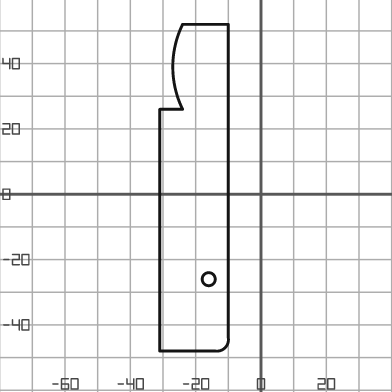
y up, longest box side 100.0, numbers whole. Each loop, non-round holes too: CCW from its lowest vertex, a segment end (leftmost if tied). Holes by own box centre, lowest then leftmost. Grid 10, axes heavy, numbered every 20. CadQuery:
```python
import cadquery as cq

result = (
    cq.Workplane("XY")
    .moveTo(-31.0, -48.0)
    .lineTo(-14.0, -48.0)
    .threePointArc((-11.0, -47.0), (-10.0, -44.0))
    .lineTo(-10.0, 52.0)
    .lineTo(-24.0, 52.0)
    .threePointArc((-27.0, 39.0), (-24.0, 26.0))
    .lineTo(-31.0, 26.0)
    .close()
    .moveTo(-16.0, -26.0)
    .circle(2.0)
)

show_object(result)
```